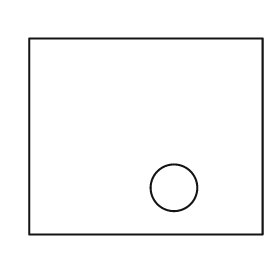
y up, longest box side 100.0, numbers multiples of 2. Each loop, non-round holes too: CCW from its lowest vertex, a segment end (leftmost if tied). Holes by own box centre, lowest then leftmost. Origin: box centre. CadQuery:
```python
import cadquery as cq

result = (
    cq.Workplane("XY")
    .moveTo(-50.0, -42.0)
    .lineTo(50.0, -42.0)
    .lineTo(50.0, 42.0)
    .lineTo(-50.0, 42.0)
    .close()
    .moveTo(12.0, -22.0)
    .circle(10.0)
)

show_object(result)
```